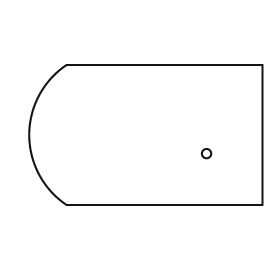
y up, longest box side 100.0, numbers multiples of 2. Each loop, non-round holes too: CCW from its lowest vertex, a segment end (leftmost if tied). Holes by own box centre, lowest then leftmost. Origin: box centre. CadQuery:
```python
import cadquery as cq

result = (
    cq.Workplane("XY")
    .moveTo(-34.0, -30.0)
    .lineTo(50.0, -30.0)
    .lineTo(50.0, 30.0)
    .lineTo(-34.0, 30.0)
    .threePointArc((-50.0, 0.0), (-34.0, -30.0))
    .close()
    .moveTo(26.0, -8.0)
    .circle(2.0)
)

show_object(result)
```